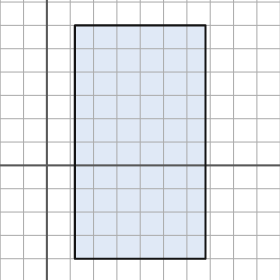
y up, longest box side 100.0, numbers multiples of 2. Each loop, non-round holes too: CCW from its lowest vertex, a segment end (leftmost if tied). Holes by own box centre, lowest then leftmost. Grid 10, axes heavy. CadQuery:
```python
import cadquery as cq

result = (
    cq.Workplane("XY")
    .moveTo(12.0, -40.0)
    .lineTo(68.0, -40.0)
    .lineTo(68.0, 60.0)
    .lineTo(12.0, 60.0)
    .close()
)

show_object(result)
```